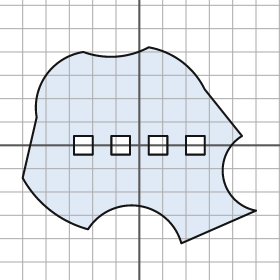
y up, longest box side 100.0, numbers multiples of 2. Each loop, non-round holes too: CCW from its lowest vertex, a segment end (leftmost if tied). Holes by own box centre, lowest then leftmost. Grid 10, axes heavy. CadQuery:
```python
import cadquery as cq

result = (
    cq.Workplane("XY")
    .moveTo(18.0, -42.0)
    .lineTo(50.0, -28.0)
    .threePointArc((36.0, -14.0), (44.0, 4.0))
    .lineTo(28.0, 24.0)
    .threePointArc((18.0, 36.0), (4.0, 42.0))
    .threePointArc((-10.0, 38.0), (-24.0, 40.0))
    .threePointArc((-40.0, 30.0), (-44.0, 12.0))
    .lineTo(-50.0, -14.0)
    .threePointArc((-38.0, -28.0), (-22.0, -36.0))
    .threePointArc((0.0, -26.0), (18.0, -42.0))
    .close()
    .moveTo(-28.0, -4.0)
    .lineTo(-20.0, -4.0)
    .lineTo(-20.0, 4.0)
    .lineTo(-28.0, 4.0)
    .close()
    .moveTo(-12.0, -4.0)
    .lineTo(-4.0, -4.0)
    .lineTo(-4.0, 4.0)
    .lineTo(-12.0, 4.0)
    .close()
    .moveTo(4.0, -4.0)
    .lineTo(12.0, -4.0)
    .lineTo(12.0, 4.0)
    .lineTo(4.0, 4.0)
    .close()
    .moveTo(20.0, -4.0)
    .lineTo(28.0, -4.0)
    .lineTo(28.0, 4.0)
    .lineTo(20.0, 4.0)
    .close()
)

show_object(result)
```